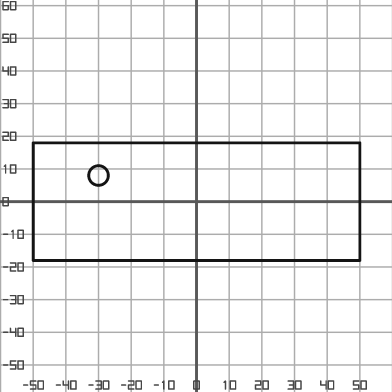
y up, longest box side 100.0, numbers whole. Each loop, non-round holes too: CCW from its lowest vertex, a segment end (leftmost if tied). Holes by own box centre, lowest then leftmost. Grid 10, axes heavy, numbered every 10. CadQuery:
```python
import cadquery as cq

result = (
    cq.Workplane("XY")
    .moveTo(-50.0, -18.0)
    .lineTo(50.0, -18.0)
    .lineTo(50.0, 18.0)
    .lineTo(-50.0, 18.0)
    .close()
    .moveTo(-30.0, 8.0)
    .circle(3.0)
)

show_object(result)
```